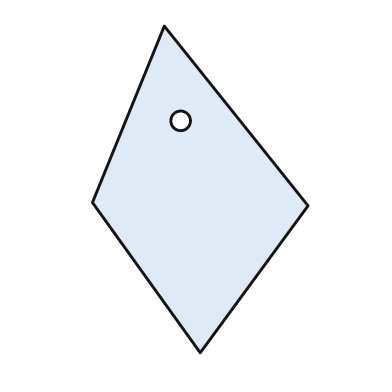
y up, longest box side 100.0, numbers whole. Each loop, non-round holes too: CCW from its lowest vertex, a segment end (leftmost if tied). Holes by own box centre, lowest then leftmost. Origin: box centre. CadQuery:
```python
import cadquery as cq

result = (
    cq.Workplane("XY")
    .moveTo(0.0, -50.0)
    .lineTo(33.0, -5.0)
    .lineTo(-11.0, 50.0)
    .lineTo(-33.0, -4.0)
    .close()
    .moveTo(-6.0, 21.0)
    .circle(3.0)
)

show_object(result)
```